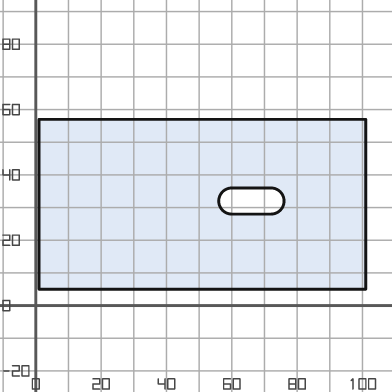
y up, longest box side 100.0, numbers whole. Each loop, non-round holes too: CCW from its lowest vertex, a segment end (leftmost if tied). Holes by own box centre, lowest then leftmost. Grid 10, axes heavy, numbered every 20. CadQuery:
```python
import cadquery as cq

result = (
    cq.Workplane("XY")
    .moveTo(1.0, 5.0)
    .lineTo(101.0, 5.0)
    .lineTo(101.0, 57.0)
    .lineTo(1.0, 57.0)
    .close()
    .moveTo(60.0, 28.0)
    .lineTo(72.0, 28.0)
    .threePointArc((76.0, 32.0), (72.0, 36.0))
    .lineTo(60.0, 36.0)
    .threePointArc((56.0, 32.0), (60.0, 28.0))
    .close()
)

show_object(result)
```